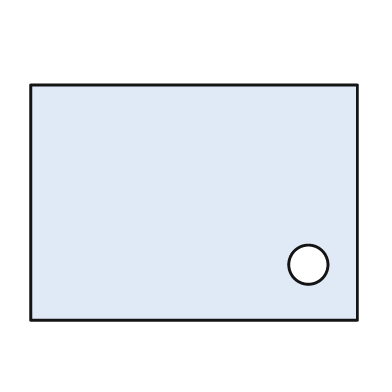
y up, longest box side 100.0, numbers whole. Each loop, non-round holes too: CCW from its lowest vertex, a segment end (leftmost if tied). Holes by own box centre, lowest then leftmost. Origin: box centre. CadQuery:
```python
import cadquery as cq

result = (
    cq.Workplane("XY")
    .moveTo(-50.0, -36.0)
    .lineTo(50.0, -36.0)
    .lineTo(50.0, 36.0)
    .lineTo(-50.0, 36.0)
    .close()
    .moveTo(35.0, -19.0)
    .circle(6.0)
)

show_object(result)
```